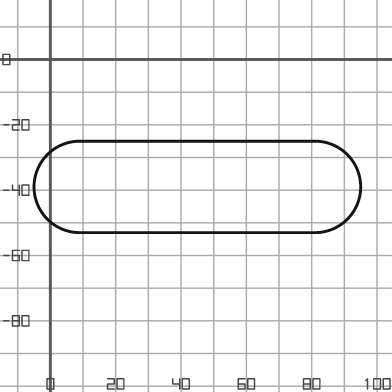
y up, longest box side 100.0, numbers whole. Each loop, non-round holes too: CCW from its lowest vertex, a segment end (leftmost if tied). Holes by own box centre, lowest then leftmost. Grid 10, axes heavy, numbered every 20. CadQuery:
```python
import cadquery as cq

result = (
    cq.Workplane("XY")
    .moveTo(9.0, -53.0)
    .lineTo(81.0, -53.0)
    .threePointArc((95.0, -39.0), (81.0, -25.0))
    .lineTo(9.0, -25.0)
    .threePointArc((-5.0, -39.0), (9.0, -53.0))
    .close()
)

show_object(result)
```